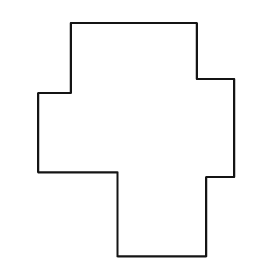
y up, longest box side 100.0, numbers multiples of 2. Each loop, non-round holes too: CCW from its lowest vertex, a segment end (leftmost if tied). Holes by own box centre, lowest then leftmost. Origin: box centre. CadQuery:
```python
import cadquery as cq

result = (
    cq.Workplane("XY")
    .moveTo(-8.0, -50.0)
    .lineTo(30.0, -50.0)
    .lineTo(30.0, -16.0)
    .lineTo(42.0, -16.0)
    .lineTo(42.0, 26.0)
    .lineTo(26.0, 26.0)
    .lineTo(26.0, 50.0)
    .lineTo(-28.0, 50.0)
    .lineTo(-28.0, 20.0)
    .lineTo(-42.0, 20.0)
    .lineTo(-42.0, -14.0)
    .lineTo(-8.0, -14.0)
    .close()
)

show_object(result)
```